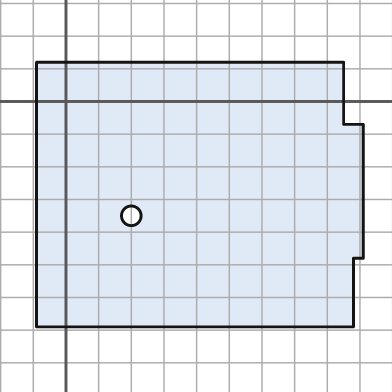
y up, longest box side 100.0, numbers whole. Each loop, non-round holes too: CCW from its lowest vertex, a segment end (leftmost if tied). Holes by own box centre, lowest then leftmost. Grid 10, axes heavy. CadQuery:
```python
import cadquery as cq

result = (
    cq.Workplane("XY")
    .moveTo(-9.0, -69.0)
    .lineTo(88.0, -69.0)
    .lineTo(88.0, -48.0)
    .lineTo(91.0, -48.0)
    .lineTo(91.0, -7.0)
    .lineTo(85.0, -7.0)
    .lineTo(85.0, 12.0)
    .lineTo(-9.0, 12.0)
    .close()
    .moveTo(20.0, -35.0)
    .circle(3.0)
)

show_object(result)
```